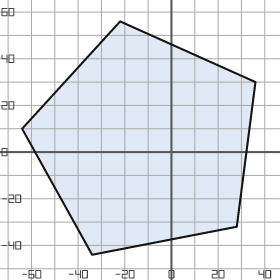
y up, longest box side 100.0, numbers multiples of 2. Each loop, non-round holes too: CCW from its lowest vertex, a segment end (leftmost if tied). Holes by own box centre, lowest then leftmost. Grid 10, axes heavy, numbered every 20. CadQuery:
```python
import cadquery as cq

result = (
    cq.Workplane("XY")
    .moveTo(-34.0, -44.0)
    .lineTo(28.0, -32.0)
    .lineTo(36.0, 30.0)
    .lineTo(-22.0, 56.0)
    .lineTo(-64.0, 10.0)
    .close()
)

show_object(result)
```